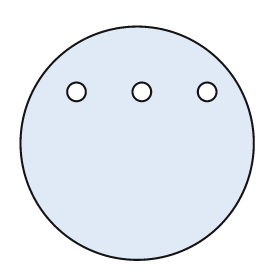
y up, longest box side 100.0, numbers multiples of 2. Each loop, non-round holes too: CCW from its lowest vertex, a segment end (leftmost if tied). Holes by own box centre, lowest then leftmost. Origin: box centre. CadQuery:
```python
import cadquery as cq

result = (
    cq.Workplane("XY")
    .moveTo(0.0, 0.0)
    .circle(50.0)
    .moveTo(-26.0, 22.0)
    .circle(4.0)
    .moveTo(2.0, 22.0)
    .circle(4.0)
    .moveTo(30.0, 22.0)
    .circle(4.0)
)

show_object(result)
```